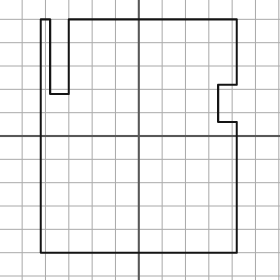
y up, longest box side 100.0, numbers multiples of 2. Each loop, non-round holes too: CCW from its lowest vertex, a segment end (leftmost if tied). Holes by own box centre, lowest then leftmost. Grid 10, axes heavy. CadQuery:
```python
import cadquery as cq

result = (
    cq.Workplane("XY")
    .moveTo(-42.0, -50.0)
    .lineTo(42.0, -50.0)
    .lineTo(42.0, 6.0)
    .lineTo(34.0, 6.0)
    .lineTo(34.0, 22.0)
    .lineTo(42.0, 22.0)
    .lineTo(42.0, 50.0)
    .lineTo(-30.0, 50.0)
    .lineTo(-30.0, 18.0)
    .lineTo(-38.0, 18.0)
    .lineTo(-38.0, 50.0)
    .lineTo(-42.0, 50.0)
    .close()
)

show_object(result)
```